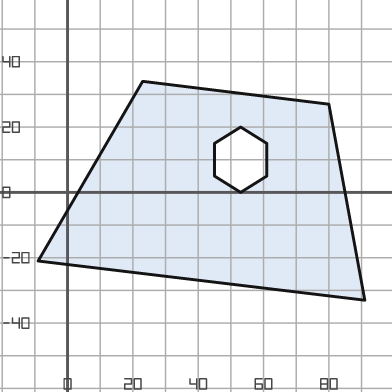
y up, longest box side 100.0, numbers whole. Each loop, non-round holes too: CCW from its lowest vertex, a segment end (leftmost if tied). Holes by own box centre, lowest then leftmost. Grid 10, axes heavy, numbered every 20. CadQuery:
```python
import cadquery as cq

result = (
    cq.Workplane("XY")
    .moveTo(91.0, -33.0)
    .lineTo(80.0, 27.0)
    .lineTo(23.0, 34.0)
    .lineTo(-9.0, -21.0)
    .close()
    .moveTo(53.0, 0.0)
    .lineTo(61.0, 5.0)
    .lineTo(61.0, 15.0)
    .lineTo(53.0, 20.0)
    .lineTo(45.0, 15.0)
    .lineTo(45.0, 5.0)
    .close()
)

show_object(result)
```